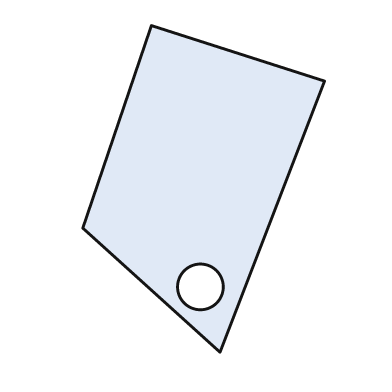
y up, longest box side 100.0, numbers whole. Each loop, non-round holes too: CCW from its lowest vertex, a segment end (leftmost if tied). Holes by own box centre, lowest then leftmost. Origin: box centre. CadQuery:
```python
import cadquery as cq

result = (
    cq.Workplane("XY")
    .moveTo(5.0, -50.0)
    .lineTo(37.0, 33.0)
    .lineTo(-16.0, 50.0)
    .lineTo(-37.0, -12.0)
    .close()
    .moveTo(-1.0, -30.0)
    .circle(7.0)
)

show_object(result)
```